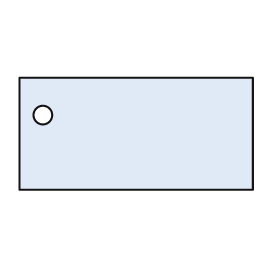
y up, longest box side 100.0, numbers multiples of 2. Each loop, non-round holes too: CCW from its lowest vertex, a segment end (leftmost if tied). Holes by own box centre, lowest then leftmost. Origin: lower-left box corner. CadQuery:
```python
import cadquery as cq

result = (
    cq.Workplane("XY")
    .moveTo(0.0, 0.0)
    .lineTo(100.0, 0.0)
    .lineTo(100.0, 48.0)
    .lineTo(0.0, 48.0)
    .close()
    .moveTo(10.0, 32.0)
    .circle(4.0)
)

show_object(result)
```